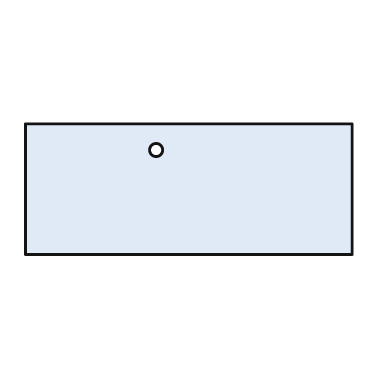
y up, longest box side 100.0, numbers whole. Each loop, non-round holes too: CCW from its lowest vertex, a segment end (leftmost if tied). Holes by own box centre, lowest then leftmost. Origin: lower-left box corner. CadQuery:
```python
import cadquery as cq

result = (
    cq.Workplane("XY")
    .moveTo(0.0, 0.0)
    .lineTo(100.0, 0.0)
    .lineTo(100.0, 40.0)
    .lineTo(0.0, 40.0)
    .close()
    .moveTo(40.0, 32.0)
    .circle(2.0)
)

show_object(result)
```